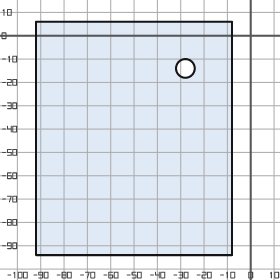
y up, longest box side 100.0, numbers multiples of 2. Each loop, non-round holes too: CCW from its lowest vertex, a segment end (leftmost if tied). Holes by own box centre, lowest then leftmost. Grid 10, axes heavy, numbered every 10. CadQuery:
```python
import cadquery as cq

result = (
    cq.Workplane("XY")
    .moveTo(-92.0, -94.0)
    .lineTo(-8.0, -94.0)
    .lineTo(-8.0, 6.0)
    .lineTo(-92.0, 6.0)
    .close()
    .moveTo(-28.0, -14.0)
    .circle(4.0)
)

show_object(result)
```